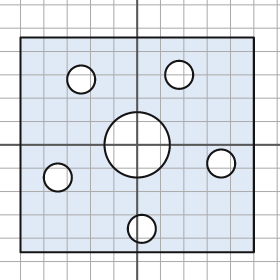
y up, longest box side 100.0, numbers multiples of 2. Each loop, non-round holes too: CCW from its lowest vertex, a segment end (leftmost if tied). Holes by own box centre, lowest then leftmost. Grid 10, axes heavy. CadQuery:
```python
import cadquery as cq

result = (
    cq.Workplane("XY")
    .moveTo(-50.0, -46.0)
    .lineTo(50.0, -46.0)
    .lineTo(50.0, 46.0)
    .lineTo(-50.0, 46.0)
    .close()
    .moveTo(2.0, -36.0)
    .circle(6.0)
    .moveTo(-34.0, -14.0)
    .circle(6.0)
    .moveTo(36.0, -8.0)
    .circle(6.0)
    .moveTo(0.0, 0.0)
    .circle(14.0)
    .moveTo(-24.0, 28.0)
    .circle(6.0)
    .moveTo(18.0, 30.0)
    .circle(6.0)
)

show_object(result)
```